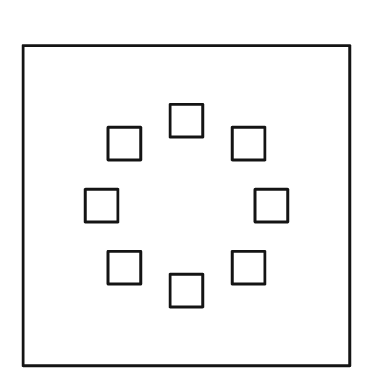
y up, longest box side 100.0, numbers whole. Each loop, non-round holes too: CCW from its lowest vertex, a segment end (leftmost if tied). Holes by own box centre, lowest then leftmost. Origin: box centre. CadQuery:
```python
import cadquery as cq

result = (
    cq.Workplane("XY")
    .moveTo(-50.0, -49.0)
    .lineTo(50.0, -49.0)
    .lineTo(50.0, 49.0)
    .lineTo(-50.0, 49.0)
    .close()
    .moveTo(-5.0, -31.0)
    .lineTo(5.0, -31.0)
    .lineTo(5.0, -21.0)
    .lineTo(-5.0, -21.0)
    .close()
    .moveTo(-24.0, -24.0)
    .lineTo(-14.0, -24.0)
    .lineTo(-14.0, -14.0)
    .lineTo(-24.0, -14.0)
    .close()
    .moveTo(14.0, -24.0)
    .lineTo(24.0, -24.0)
    .lineTo(24.0, -14.0)
    .lineTo(14.0, -14.0)
    .close()
    .moveTo(-31.0, -5.0)
    .lineTo(-21.0, -5.0)
    .lineTo(-21.0, 5.0)
    .lineTo(-31.0, 5.0)
    .close()
    .moveTo(21.0, -5.0)
    .lineTo(31.0, -5.0)
    .lineTo(31.0, 5.0)
    .lineTo(21.0, 5.0)
    .close()
    .moveTo(-24.0, 14.0)
    .lineTo(-14.0, 14.0)
    .lineTo(-14.0, 24.0)
    .lineTo(-24.0, 24.0)
    .close()
    .moveTo(14.0, 14.0)
    .lineTo(24.0, 14.0)
    .lineTo(24.0, 24.0)
    .lineTo(14.0, 24.0)
    .close()
    .moveTo(-5.0, 21.0)
    .lineTo(5.0, 21.0)
    .lineTo(5.0, 31.0)
    .lineTo(-5.0, 31.0)
    .close()
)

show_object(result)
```